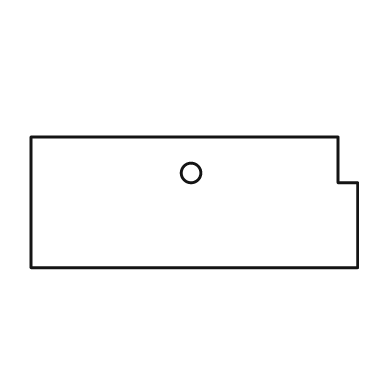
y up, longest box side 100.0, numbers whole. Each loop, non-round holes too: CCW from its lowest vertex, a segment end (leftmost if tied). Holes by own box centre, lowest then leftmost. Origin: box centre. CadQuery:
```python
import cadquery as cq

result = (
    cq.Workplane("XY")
    .moveTo(-50.0, -20.0)
    .lineTo(50.0, -20.0)
    .lineTo(50.0, 6.0)
    .lineTo(44.0, 6.0)
    .lineTo(44.0, 20.0)
    .lineTo(-50.0, 20.0)
    .close()
    .moveTo(-1.0, 9.0)
    .circle(3.0)
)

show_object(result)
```